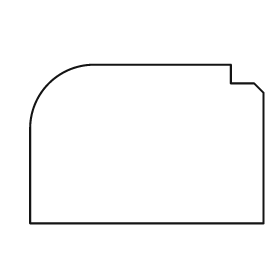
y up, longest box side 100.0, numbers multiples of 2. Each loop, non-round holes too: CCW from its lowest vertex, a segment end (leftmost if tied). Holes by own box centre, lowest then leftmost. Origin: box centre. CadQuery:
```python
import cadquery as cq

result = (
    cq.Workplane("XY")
    .moveTo(-50.0, -34.0)
    .lineTo(50.0, -34.0)
    .lineTo(50.0, 22.0)
    .lineTo(46.0, 26.0)
    .lineTo(36.0, 26.0)
    .lineTo(36.0, 34.0)
    .lineTo(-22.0, 34.0)
    .threePointArc((-42.0, 26.0), (-50.0, 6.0))
    .close()
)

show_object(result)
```